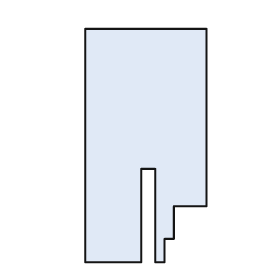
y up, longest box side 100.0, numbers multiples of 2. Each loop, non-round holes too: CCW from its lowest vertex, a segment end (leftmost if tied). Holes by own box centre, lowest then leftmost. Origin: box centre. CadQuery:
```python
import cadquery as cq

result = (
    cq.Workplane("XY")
    .moveTo(-26.0, -50.0)
    .lineTo(-2.0, -50.0)
    .lineTo(-2.0, -10.0)
    .lineTo(4.0, -10.0)
    .lineTo(4.0, -50.0)
    .lineTo(8.0, -50.0)
    .lineTo(8.0, -40.0)
    .lineTo(12.0, -40.0)
    .lineTo(12.0, -26.0)
    .lineTo(26.0, -26.0)
    .lineTo(26.0, 50.0)
    .lineTo(-26.0, 50.0)
    .close()
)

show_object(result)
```